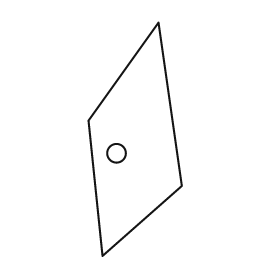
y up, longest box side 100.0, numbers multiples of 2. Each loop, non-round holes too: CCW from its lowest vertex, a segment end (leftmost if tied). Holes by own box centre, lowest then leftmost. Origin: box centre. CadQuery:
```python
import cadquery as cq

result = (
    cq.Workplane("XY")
    .moveTo(-14.0, -50.0)
    .lineTo(20.0, -20.0)
    .lineTo(10.0, 50.0)
    .lineTo(-20.0, 8.0)
    .close()
    .moveTo(-8.0, -6.0)
    .circle(4.0)
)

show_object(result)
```